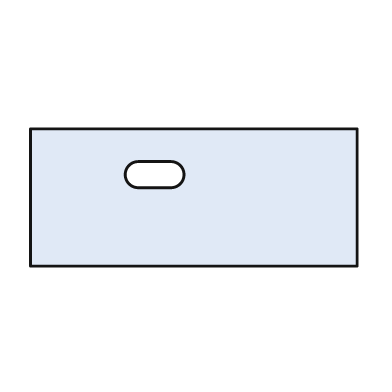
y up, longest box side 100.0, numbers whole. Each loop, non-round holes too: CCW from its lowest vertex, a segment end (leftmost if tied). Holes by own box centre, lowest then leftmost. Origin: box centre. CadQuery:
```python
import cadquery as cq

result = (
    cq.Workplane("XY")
    .moveTo(-50.0, -21.0)
    .lineTo(50.0, -21.0)
    .lineTo(50.0, 21.0)
    .lineTo(-50.0, 21.0)
    .close()
    .moveTo(-17.0, 3.0)
    .lineTo(-7.0, 3.0)
    .threePointArc((-3.0, 7.0), (-7.0, 11.0))
    .lineTo(-17.0, 11.0)
    .threePointArc((-21.0, 7.0), (-17.0, 3.0))
    .close()
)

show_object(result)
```